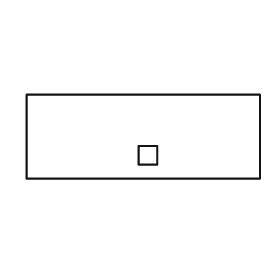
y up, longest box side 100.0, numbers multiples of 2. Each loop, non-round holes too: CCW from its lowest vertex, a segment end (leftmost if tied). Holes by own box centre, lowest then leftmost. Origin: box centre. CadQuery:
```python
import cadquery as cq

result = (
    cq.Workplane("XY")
    .moveTo(-50.0, -18.0)
    .lineTo(50.0, -18.0)
    .lineTo(50.0, 18.0)
    .lineTo(-50.0, 18.0)
    .close()
    .moveTo(-2.0, -12.0)
    .lineTo(6.0, -12.0)
    .lineTo(6.0, -4.0)
    .lineTo(-2.0, -4.0)
    .close()
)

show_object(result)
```